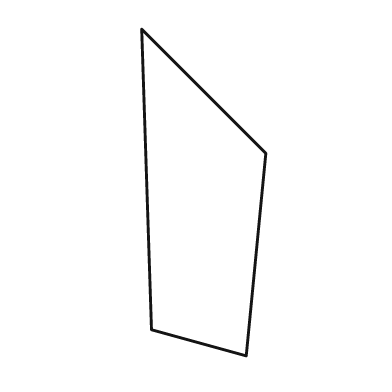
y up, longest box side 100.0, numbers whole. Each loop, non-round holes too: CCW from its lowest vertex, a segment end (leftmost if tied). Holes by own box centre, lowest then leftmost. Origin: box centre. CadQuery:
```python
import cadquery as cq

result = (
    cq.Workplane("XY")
    .moveTo(13.0, -50.0)
    .lineTo(19.0, 12.0)
    .lineTo(-19.0, 50.0)
    .lineTo(-16.0, -42.0)
    .close()
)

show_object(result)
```